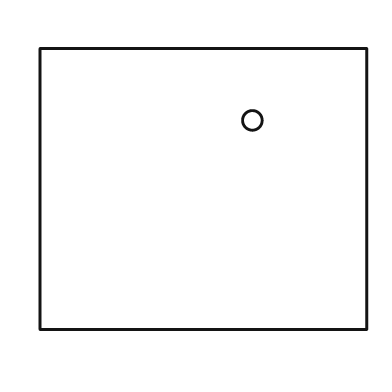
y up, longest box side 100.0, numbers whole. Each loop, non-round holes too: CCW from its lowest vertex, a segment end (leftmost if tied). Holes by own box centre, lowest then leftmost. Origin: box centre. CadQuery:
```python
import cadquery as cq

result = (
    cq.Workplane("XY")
    .moveTo(-50.0, -43.0)
    .lineTo(50.0, -43.0)
    .lineTo(50.0, 43.0)
    .lineTo(-50.0, 43.0)
    .close()
    .moveTo(15.0, 21.0)
    .circle(3.0)
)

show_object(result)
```